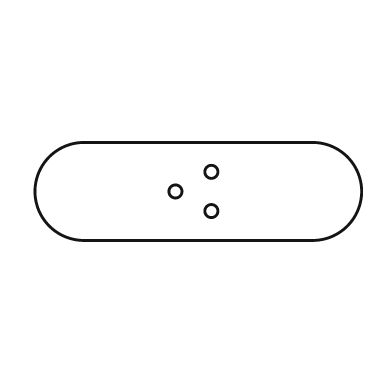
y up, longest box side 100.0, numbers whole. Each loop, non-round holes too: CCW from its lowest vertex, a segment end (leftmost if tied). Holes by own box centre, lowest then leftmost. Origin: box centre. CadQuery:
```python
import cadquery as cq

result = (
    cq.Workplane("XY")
    .moveTo(-35.0, -15.0)
    .lineTo(35.0, -15.0)
    .threePointArc((50.0, 0.0), (35.0, 15.0))
    .lineTo(-35.0, 15.0)
    .threePointArc((-50.0, 0.0), (-35.0, -15.0))
    .close()
    .moveTo(4.0, -6.0)
    .circle(2.0)
    .moveTo(-7.0, 0.0)
    .circle(2.0)
    .moveTo(4.0, 6.0)
    .circle(2.0)
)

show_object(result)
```